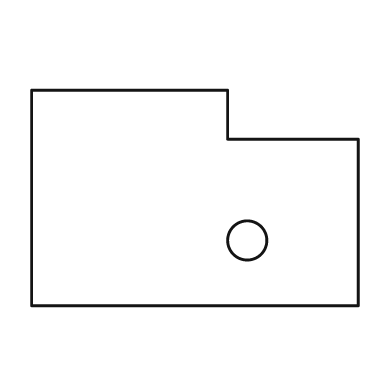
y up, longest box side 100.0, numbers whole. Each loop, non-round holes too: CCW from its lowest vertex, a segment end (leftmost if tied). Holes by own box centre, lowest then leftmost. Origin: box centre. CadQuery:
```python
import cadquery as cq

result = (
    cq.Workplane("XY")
    .moveTo(-50.0, -33.0)
    .lineTo(50.0, -33.0)
    .lineTo(50.0, 18.0)
    .lineTo(10.0, 18.0)
    .lineTo(10.0, 33.0)
    .lineTo(-50.0, 33.0)
    .close()
    .moveTo(16.0, -13.0)
    .circle(6.0)
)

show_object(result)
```